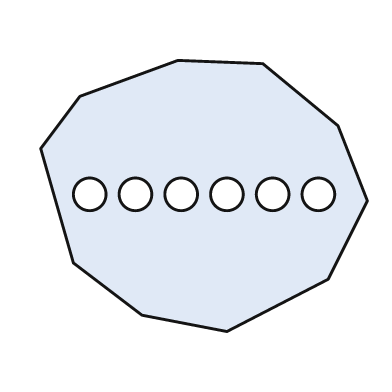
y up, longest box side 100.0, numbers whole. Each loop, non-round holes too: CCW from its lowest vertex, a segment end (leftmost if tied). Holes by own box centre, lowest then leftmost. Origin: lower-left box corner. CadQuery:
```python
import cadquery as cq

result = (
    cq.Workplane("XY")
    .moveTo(57.0, 0.0)
    .lineTo(88.0, 16.0)
    .lineTo(100.0, 40.0)
    .lineTo(91.0, 63.0)
    .lineTo(68.0, 82.0)
    .lineTo(42.0, 83.0)
    .lineTo(12.0, 72.0)
    .lineTo(0.0, 56.0)
    .lineTo(10.0, 21.0)
    .lineTo(31.0, 5.0)
    .close()
    .moveTo(15.0, 42.0)
    .circle(5.0)
    .moveTo(29.0, 42.0)
    .circle(5.0)
    .moveTo(43.0, 42.0)
    .circle(5.0)
    .moveTo(57.0, 42.0)
    .circle(5.0)
    .moveTo(71.0, 42.0)
    .circle(5.0)
    .moveTo(85.0, 42.0)
    .circle(5.0)
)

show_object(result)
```